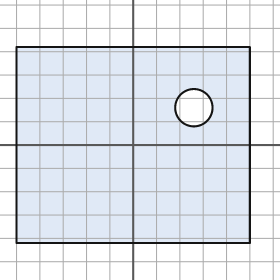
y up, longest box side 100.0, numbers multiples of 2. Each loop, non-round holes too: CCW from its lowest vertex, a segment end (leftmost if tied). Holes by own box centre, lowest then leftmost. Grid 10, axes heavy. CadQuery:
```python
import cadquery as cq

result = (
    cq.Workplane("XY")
    .moveTo(-50.0, -42.0)
    .lineTo(50.0, -42.0)
    .lineTo(50.0, 42.0)
    .lineTo(-50.0, 42.0)
    .close()
    .moveTo(26.0, 16.0)
    .circle(8.0)
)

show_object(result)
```